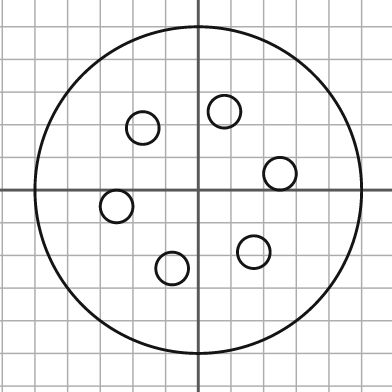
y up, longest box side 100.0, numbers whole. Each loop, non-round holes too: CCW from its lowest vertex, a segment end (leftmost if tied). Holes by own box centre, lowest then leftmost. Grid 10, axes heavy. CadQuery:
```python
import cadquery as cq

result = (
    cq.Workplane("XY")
    .moveTo(0.0, 0.0)
    .circle(50.0)
    .moveTo(-8.0, -24.0)
    .circle(5.0)
    .moveTo(17.0, -19.0)
    .circle(5.0)
    .moveTo(-25.0, -5.0)
    .circle(5.0)
    .moveTo(25.0, 5.0)
    .circle(5.0)
    .moveTo(-17.0, 19.0)
    .circle(5.0)
    .moveTo(8.0, 24.0)
    .circle(5.0)
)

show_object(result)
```